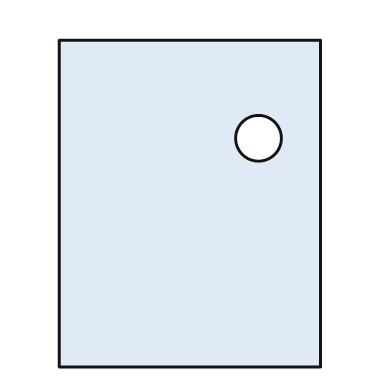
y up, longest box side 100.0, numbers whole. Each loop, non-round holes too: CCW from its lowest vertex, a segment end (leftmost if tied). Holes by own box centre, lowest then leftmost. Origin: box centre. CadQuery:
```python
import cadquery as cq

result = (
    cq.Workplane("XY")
    .moveTo(-40.0, -50.0)
    .lineTo(40.0, -50.0)
    .lineTo(40.0, 50.0)
    .lineTo(-40.0, 50.0)
    .close()
    .moveTo(21.0, 20.0)
    .circle(7.0)
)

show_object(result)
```